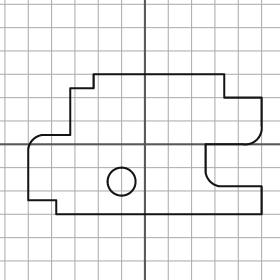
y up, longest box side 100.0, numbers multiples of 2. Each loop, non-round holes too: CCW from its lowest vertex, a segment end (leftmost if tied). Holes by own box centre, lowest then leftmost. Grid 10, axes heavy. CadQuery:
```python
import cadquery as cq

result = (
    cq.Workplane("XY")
    .moveTo(-38.0, -30.0)
    .lineTo(50.0, -30.0)
    .lineTo(50.0, -18.0)
    .lineTo(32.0, -18.0)
    .threePointArc((28.0, -16.0), (26.0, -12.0))
    .lineTo(26.0, 0.0)
    .lineTo(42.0, 0.0)
    .threePointArc((48.0, 2.0), (50.0, 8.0))
    .lineTo(50.0, 20.0)
    .lineTo(34.0, 20.0)
    .lineTo(34.0, 30.0)
    .lineTo(-22.0, 30.0)
    .lineTo(-22.0, 24.0)
    .lineTo(-32.0, 24.0)
    .lineTo(-32.0, 4.0)
    .lineTo(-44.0, 4.0)
    .threePointArc((-48.0, 2.0), (-50.0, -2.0))
    .lineTo(-50.0, -24.0)
    .lineTo(-38.0, -24.0)
    .close()
    .moveTo(-10.0, -16.0)
    .circle(6.0)
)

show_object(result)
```